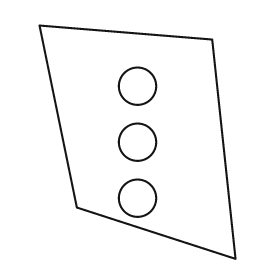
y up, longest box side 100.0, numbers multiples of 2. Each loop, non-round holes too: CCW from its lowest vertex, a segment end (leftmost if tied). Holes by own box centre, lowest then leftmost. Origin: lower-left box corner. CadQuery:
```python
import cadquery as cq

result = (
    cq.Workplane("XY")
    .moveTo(84.0, 0.0)
    .lineTo(74.0, 94.0)
    .lineTo(0.0, 100.0)
    .lineTo(16.0, 22.0)
    .close()
    .moveTo(42.0, 26.0)
    .circle(8.0)
    .moveTo(42.0, 50.0)
    .circle(8.0)
    .moveTo(42.0, 74.0)
    .circle(8.0)
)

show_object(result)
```